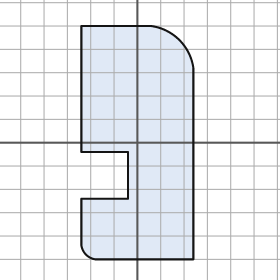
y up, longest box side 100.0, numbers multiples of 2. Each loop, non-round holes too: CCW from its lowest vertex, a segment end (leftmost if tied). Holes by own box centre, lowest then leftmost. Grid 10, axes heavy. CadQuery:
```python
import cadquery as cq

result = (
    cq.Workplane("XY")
    .moveTo(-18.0, -50.0)
    .lineTo(24.0, -50.0)
    .lineTo(24.0, 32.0)
    .threePointArc((18.0, 44.0), (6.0, 50.0))
    .lineTo(-24.0, 50.0)
    .lineTo(-24.0, -4.0)
    .lineTo(-4.0, -4.0)
    .lineTo(-4.0, -24.0)
    .lineTo(-24.0, -24.0)
    .lineTo(-24.0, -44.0)
    .threePointArc((-22.0, -48.0), (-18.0, -50.0))
    .close()
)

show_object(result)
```